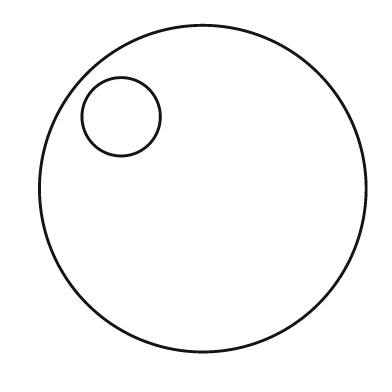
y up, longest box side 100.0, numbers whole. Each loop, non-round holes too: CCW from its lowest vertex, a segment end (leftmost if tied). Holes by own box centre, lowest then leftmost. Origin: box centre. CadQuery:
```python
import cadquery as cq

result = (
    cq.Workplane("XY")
    .moveTo(0.0, 0.0)
    .circle(50.0)
    .moveTo(-25.0, 22.0)
    .circle(12.0)
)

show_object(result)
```